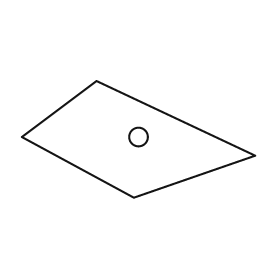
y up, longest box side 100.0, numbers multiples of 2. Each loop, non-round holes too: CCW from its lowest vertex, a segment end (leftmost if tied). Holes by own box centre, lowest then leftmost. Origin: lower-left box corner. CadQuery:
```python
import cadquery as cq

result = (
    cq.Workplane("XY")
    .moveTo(48.0, 0.0)
    .lineTo(100.0, 18.0)
    .lineTo(32.0, 50.0)
    .lineTo(0.0, 26.0)
    .close()
    .moveTo(50.0, 26.0)
    .circle(4.0)
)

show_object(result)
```